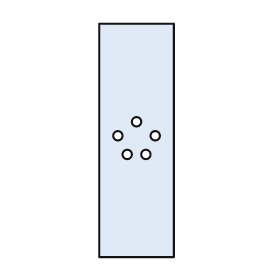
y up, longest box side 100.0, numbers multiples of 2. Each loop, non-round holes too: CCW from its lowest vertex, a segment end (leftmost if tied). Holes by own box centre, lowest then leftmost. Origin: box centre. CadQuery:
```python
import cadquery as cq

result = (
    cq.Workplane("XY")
    .moveTo(-16.0, -50.0)
    .lineTo(16.0, -50.0)
    .lineTo(16.0, 50.0)
    .lineTo(-16.0, 50.0)
    .close()
    .moveTo(-4.0, -6.0)
    .circle(2.0)
    .moveTo(4.0, -6.0)
    .circle(2.0)
    .moveTo(-8.0, 2.0)
    .circle(2.0)
    .moveTo(8.0, 2.0)
    .circle(2.0)
    .moveTo(0.0, 8.0)
    .circle(2.0)
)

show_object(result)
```